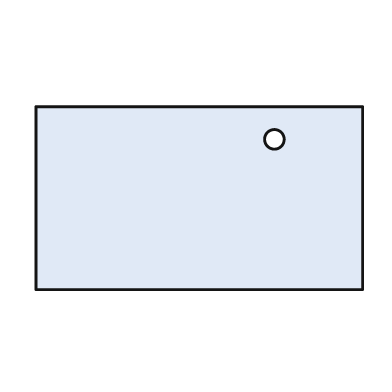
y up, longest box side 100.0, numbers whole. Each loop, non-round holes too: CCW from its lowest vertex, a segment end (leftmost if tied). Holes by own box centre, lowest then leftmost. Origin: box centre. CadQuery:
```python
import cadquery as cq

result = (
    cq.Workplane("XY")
    .moveTo(-50.0, -28.0)
    .lineTo(50.0, -28.0)
    .lineTo(50.0, 28.0)
    .lineTo(-50.0, 28.0)
    .close()
    .moveTo(23.0, 18.0)
    .circle(3.0)
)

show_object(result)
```